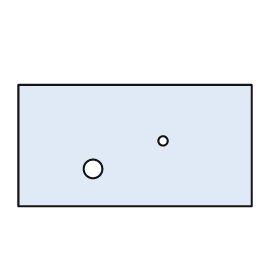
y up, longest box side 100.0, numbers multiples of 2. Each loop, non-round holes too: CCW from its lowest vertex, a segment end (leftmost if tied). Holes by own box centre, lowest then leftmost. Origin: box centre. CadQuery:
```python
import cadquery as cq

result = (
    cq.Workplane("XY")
    .moveTo(-50.0, -26.0)
    .lineTo(50.0, -26.0)
    .lineTo(50.0, 26.0)
    .lineTo(-50.0, 26.0)
    .close()
    .moveTo(-18.0, -10.0)
    .circle(4.0)
    .moveTo(12.0, 2.0)
    .circle(2.0)
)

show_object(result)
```